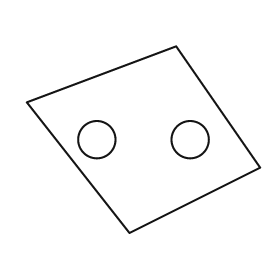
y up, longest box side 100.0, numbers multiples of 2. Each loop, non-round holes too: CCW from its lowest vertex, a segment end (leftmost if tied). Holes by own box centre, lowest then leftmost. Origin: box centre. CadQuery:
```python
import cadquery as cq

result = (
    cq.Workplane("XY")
    .moveTo(-6.0, -40.0)
    .lineTo(50.0, -12.0)
    .lineTo(14.0, 40.0)
    .lineTo(-50.0, 16.0)
    .close()
    .moveTo(-20.0, 0.0)
    .circle(8.0)
    .moveTo(20.0, 0.0)
    .circle(8.0)
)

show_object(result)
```